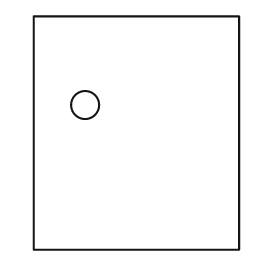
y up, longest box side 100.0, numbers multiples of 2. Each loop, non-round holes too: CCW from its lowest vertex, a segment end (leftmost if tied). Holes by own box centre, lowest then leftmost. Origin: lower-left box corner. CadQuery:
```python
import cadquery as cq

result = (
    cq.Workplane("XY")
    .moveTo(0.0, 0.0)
    .lineTo(88.0, 0.0)
    .lineTo(88.0, 100.0)
    .lineTo(0.0, 100.0)
    .close()
    .moveTo(22.0, 62.0)
    .circle(6.0)
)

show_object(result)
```